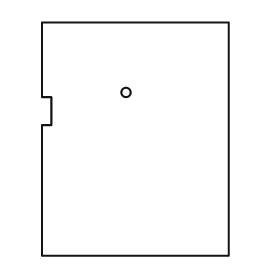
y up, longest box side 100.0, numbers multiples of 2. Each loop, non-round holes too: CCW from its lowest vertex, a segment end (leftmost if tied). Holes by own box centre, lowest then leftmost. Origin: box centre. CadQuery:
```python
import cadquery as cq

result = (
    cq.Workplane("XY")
    .moveTo(-40.0, -50.0)
    .lineTo(40.0, -50.0)
    .lineTo(40.0, 50.0)
    .lineTo(-40.0, 50.0)
    .lineTo(-40.0, 18.0)
    .lineTo(-36.0, 18.0)
    .lineTo(-36.0, 6.0)
    .lineTo(-40.0, 6.0)
    .close()
    .moveTo(-4.0, 20.0)
    .circle(2.0)
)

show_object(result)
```